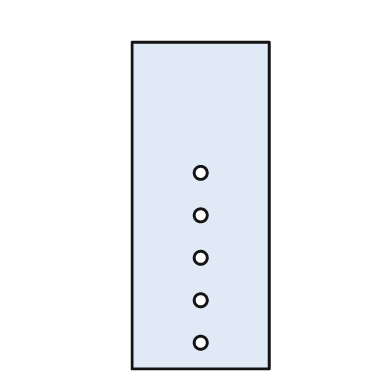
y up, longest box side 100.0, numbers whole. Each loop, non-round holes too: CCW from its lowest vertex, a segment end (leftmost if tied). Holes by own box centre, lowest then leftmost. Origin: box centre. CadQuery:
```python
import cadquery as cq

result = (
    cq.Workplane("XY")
    .moveTo(-21.0, -50.0)
    .lineTo(21.0, -50.0)
    .lineTo(21.0, 50.0)
    .lineTo(-21.0, 50.0)
    .close()
    .moveTo(0.0, -42.0)
    .circle(2.0)
    .moveTo(0.0, -29.0)
    .circle(2.0)
    .moveTo(0.0, -16.0)
    .circle(2.0)
    .moveTo(0.0, -3.0)
    .circle(2.0)
    .moveTo(0.0, 10.0)
    .circle(2.0)
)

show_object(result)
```